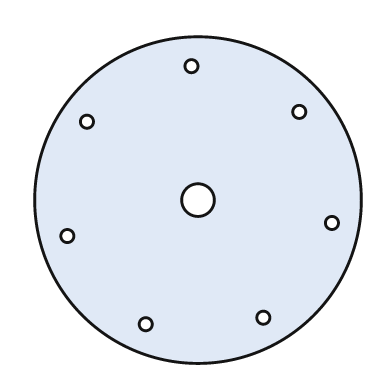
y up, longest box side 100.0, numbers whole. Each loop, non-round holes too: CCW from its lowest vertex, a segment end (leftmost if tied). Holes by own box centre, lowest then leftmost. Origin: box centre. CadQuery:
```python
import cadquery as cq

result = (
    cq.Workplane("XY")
    .moveTo(0.0, 0.0)
    .circle(50.0)
    .moveTo(-16.0, -38.0)
    .circle(2.0)
    .moveTo(20.0, -36.0)
    .circle(2.0)
    .moveTo(-40.0, -11.0)
    .circle(2.0)
    .moveTo(41.0, -7.0)
    .circle(2.0)
    .moveTo(0.0, 0.0)
    .circle(5.0)
    .moveTo(-34.0, 24.0)
    .circle(2.0)
    .moveTo(31.0, 27.0)
    .circle(2.0)
    .moveTo(-2.0, 41.0)
    .circle(2.0)
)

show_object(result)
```